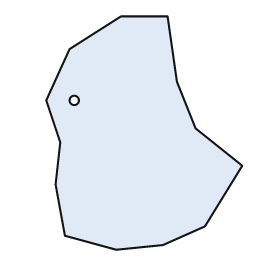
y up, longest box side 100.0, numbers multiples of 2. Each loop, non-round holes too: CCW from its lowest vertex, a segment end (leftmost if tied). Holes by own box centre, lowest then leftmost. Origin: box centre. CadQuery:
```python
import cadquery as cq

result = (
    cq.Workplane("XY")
    .moveTo(-12.0, -50.0)
    .lineTo(8.0, -48.0)
    .lineTo(26.0, -40.0)
    .lineTo(42.0, -14.0)
    .lineTo(22.0, 2.0)
    .lineTo(14.0, 22.0)
    .lineTo(10.0, 50.0)
    .lineTo(-10.0, 50.0)
    .lineTo(-32.0, 36.0)
    .lineTo(-42.0, 14.0)
    .lineTo(-36.0, -4.0)
    .lineTo(-38.0, -22.0)
    .lineTo(-34.0, -44.0)
    .close()
    .moveTo(-30.0, 14.0)
    .circle(2.0)
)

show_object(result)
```